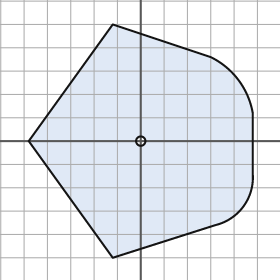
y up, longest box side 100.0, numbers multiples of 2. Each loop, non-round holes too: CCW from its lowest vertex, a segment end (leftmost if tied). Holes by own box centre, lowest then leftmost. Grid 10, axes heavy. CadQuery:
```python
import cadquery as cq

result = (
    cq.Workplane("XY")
    .moveTo(-12.0, -50.0)
    .lineTo(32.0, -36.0)
    .threePointArc((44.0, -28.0), (48.0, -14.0))
    .lineTo(48.0, 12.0)
    .threePointArc((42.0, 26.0), (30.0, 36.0))
    .lineTo(-12.0, 50.0)
    .lineTo(-48.0, 0.0)
    .close()
    .moveTo(0.0, 0.0)
    .circle(2.0)
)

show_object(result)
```